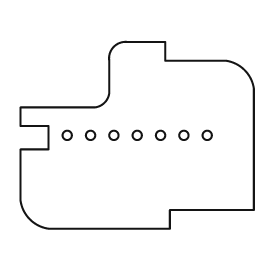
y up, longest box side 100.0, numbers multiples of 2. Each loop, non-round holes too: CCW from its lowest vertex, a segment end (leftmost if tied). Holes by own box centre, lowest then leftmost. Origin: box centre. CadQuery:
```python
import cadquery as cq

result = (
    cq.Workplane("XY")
    .moveTo(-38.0, -40.0)
    .lineTo(14.0, -40.0)
    .lineTo(14.0, -32.0)
    .lineTo(50.0, -32.0)
    .lineTo(50.0, 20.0)
    .threePointArc((46.0, 28.0), (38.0, 32.0))
    .lineTo(12.0, 32.0)
    .lineTo(12.0, 40.0)
    .lineTo(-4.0, 40.0)
    .threePointArc((-10.0, 38.0), (-12.0, 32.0))
    .lineTo(-12.0, 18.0)
    .threePointArc((-14.0, 14.0), (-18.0, 12.0))
    .lineTo(-50.0, 12.0)
    .lineTo(-50.0, 4.0)
    .lineTo(-38.0, 4.0)
    .lineTo(-38.0, -6.0)
    .lineTo(-50.0, -6.0)
    .lineTo(-50.0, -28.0)
    .threePointArc((-46.0, -36.0), (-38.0, -40.0))
    .close()
    .moveTo(-30.0, 0.0)
    .circle(2.0)
    .moveTo(-20.0, 0.0)
    .circle(2.0)
    .moveTo(-10.0, 0.0)
    .circle(2.0)
    .moveTo(0.0, 0.0)
    .circle(2.0)
    .moveTo(10.0, 0.0)
    .circle(2.0)
    .moveTo(20.0, 0.0)
    .circle(2.0)
    .moveTo(30.0, 0.0)
    .circle(2.0)
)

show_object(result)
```